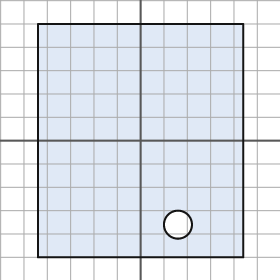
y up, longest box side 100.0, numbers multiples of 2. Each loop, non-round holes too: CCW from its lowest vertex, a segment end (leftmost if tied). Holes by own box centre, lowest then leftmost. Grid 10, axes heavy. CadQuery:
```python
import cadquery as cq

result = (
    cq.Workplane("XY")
    .moveTo(-44.0, -50.0)
    .lineTo(44.0, -50.0)
    .lineTo(44.0, 50.0)
    .lineTo(-44.0, 50.0)
    .close()
    .moveTo(16.0, -36.0)
    .circle(6.0)
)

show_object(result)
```